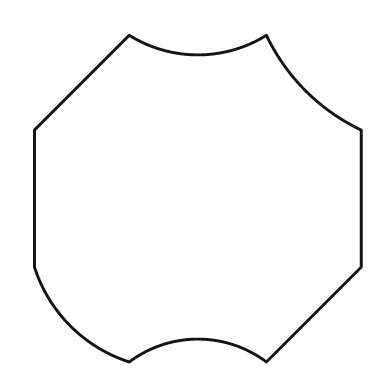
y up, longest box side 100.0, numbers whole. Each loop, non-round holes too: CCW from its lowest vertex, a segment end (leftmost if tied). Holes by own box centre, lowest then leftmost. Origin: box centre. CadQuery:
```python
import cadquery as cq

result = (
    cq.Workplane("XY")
    .moveTo(-21.0, -50.0)
    .threePointArc((0.0, -43.0), (21.0, -50.0))
    .lineTo(50.0, -21.0)
    .lineTo(50.0, 21.0)
    .threePointArc((33.0, 33.0), (21.0, 50.0))
    .threePointArc((0.0, 44.0), (-21.0, 50.0))
    .lineTo(-50.0, 21.0)
    .lineTo(-50.0, -21.0)
    .threePointArc((-39.0, -39.0), (-21.0, -50.0))
    .close()
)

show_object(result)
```